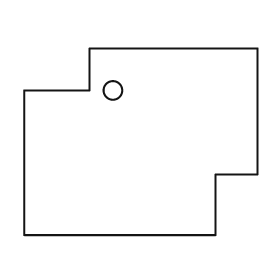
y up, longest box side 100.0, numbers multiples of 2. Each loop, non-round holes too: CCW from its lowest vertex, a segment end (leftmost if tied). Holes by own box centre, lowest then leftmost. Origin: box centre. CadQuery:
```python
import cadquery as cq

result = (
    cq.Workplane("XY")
    .moveTo(-50.0, -40.0)
    .lineTo(32.0, -40.0)
    .lineTo(32.0, -14.0)
    .lineTo(50.0, -14.0)
    .lineTo(50.0, 40.0)
    .lineTo(-22.0, 40.0)
    .lineTo(-22.0, 22.0)
    .lineTo(-50.0, 22.0)
    .close()
    .moveTo(-12.0, 22.0)
    .circle(4.0)
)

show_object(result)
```